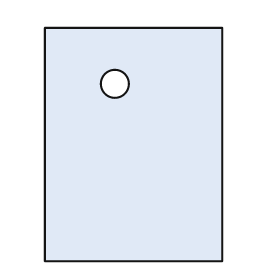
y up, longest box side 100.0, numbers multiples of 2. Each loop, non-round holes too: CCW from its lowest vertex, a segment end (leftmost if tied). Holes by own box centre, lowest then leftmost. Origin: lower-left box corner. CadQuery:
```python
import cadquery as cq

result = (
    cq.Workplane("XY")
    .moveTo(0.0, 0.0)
    .lineTo(76.0, 0.0)
    .lineTo(76.0, 100.0)
    .lineTo(0.0, 100.0)
    .close()
    .moveTo(30.0, 76.0)
    .circle(6.0)
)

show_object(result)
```